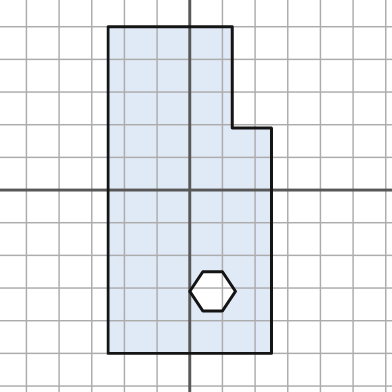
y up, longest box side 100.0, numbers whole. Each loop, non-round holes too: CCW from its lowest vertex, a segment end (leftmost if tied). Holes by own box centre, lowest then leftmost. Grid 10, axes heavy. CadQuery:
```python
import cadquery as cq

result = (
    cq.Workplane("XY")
    .moveTo(-25.0, -50.0)
    .lineTo(25.0, -50.0)
    .lineTo(25.0, 19.0)
    .lineTo(13.0, 19.0)
    .lineTo(13.0, 50.0)
    .lineTo(-25.0, 50.0)
    .close()
    .moveTo(4.0, -37.0)
    .lineTo(10.0, -37.0)
    .lineTo(14.0, -31.0)
    .lineTo(10.0, -25.0)
    .lineTo(4.0, -25.0)
    .lineTo(0.0, -31.0)
    .close()
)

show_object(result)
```